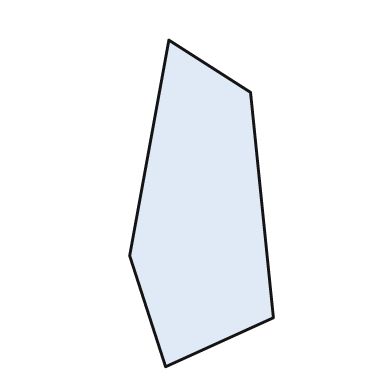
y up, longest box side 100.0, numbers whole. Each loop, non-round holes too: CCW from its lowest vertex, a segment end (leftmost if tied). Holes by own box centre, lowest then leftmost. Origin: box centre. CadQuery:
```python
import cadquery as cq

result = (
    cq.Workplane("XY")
    .moveTo(-11.0, -50.0)
    .lineTo(22.0, -35.0)
    .lineTo(15.0, 34.0)
    .lineTo(-10.0, 50.0)
    .lineTo(-22.0, -16.0)
    .close()
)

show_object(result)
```